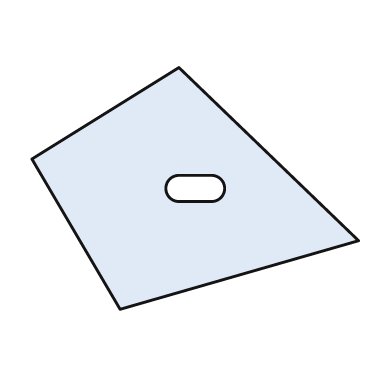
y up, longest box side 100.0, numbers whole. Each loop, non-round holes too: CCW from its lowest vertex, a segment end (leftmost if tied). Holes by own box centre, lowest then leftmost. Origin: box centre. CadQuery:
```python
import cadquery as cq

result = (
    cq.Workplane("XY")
    .moveTo(-23.0, -37.0)
    .lineTo(50.0, -16.0)
    .lineTo(-5.0, 37.0)
    .lineTo(-50.0, 9.0)
    .close()
    .moveTo(-5.0, -4.0)
    .lineTo(5.0, -4.0)
    .threePointArc((9.0, 0.0), (5.0, 4.0))
    .lineTo(-5.0, 4.0)
    .threePointArc((-9.0, 0.0), (-5.0, -4.0))
    .close()
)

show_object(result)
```